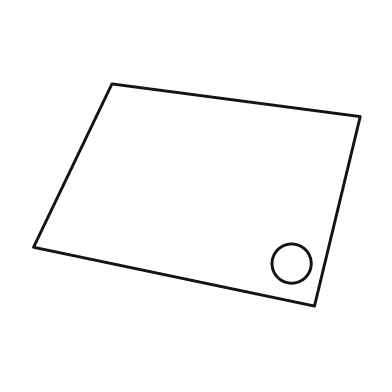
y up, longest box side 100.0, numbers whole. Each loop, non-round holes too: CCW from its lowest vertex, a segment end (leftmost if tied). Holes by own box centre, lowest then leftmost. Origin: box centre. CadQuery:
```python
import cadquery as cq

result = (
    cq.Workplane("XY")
    .moveTo(36.0, -34.0)
    .lineTo(50.0, 24.0)
    .lineTo(-26.0, 34.0)
    .lineTo(-50.0, -16.0)
    .close()
    .moveTo(29.0, -21.0)
    .circle(6.0)
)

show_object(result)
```